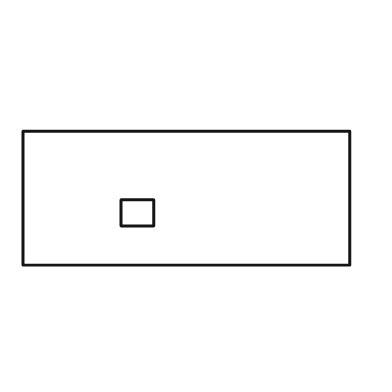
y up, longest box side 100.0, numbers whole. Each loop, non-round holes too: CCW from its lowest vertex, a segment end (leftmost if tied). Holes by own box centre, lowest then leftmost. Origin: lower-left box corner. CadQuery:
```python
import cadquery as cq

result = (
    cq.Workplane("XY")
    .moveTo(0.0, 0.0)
    .lineTo(100.0, 0.0)
    .lineTo(100.0, 41.0)
    .lineTo(0.0, 41.0)
    .close()
    .moveTo(30.0, 12.0)
    .lineTo(40.0, 12.0)
    .lineTo(40.0, 20.0)
    .lineTo(30.0, 20.0)
    .close()
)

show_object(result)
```